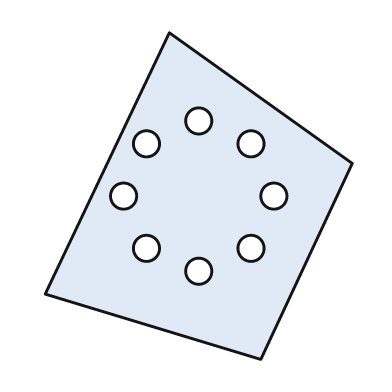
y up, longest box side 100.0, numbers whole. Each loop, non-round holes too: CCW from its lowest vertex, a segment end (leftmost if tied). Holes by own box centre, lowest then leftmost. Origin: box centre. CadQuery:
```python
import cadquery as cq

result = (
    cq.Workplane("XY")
    .moveTo(19.0, -50.0)
    .lineTo(47.0, 10.0)
    .lineTo(-9.0, 50.0)
    .lineTo(-47.0, -30.0)
    .close()
    .moveTo(0.0, -23.0)
    .circle(4.0)
    .moveTo(-16.0, -16.0)
    .circle(4.0)
    .moveTo(16.0, -16.0)
    .circle(4.0)
    .moveTo(-23.0, 0.0)
    .circle(4.0)
    .moveTo(23.0, 0.0)
    .circle(4.0)
    .moveTo(-16.0, 16.0)
    .circle(4.0)
    .moveTo(16.0, 16.0)
    .circle(4.0)
    .moveTo(0.0, 23.0)
    .circle(4.0)
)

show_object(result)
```